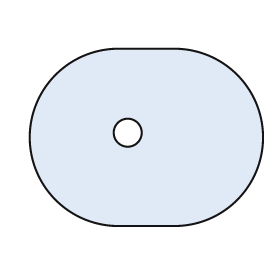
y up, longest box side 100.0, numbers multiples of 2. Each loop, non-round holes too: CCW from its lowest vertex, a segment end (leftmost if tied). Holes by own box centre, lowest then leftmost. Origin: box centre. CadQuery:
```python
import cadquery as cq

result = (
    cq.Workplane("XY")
    .moveTo(-12.0, -38.0)
    .lineTo(12.0, -38.0)
    .threePointArc((50.0, 0.0), (12.0, 38.0))
    .lineTo(-12.0, 38.0)
    .threePointArc((-50.0, 0.0), (-12.0, -38.0))
    .close()
    .moveTo(-8.0, 2.0)
    .circle(6.0)
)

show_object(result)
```